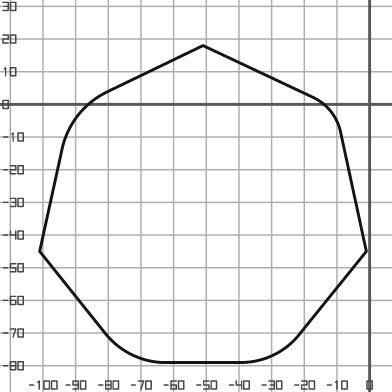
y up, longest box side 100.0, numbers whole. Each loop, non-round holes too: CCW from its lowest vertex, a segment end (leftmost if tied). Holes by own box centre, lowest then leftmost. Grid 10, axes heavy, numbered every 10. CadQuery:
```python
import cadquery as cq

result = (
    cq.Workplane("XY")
    .moveTo(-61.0, -79.0)
    .lineTo(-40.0, -79.0)
    .threePointArc((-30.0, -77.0), (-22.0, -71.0))
    .lineTo(-1.0, -45.0)
    .lineTo(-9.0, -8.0)
    .threePointArc((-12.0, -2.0), (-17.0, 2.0))
    .lineTo(-51.0, 18.0)
    .lineTo(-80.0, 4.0)
    .threePointArc((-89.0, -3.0), (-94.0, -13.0))
    .lineTo(-101.0, -45.0)
    .lineTo(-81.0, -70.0)
    .threePointArc((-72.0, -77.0), (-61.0, -79.0))
    .close()
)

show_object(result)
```